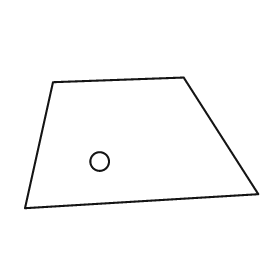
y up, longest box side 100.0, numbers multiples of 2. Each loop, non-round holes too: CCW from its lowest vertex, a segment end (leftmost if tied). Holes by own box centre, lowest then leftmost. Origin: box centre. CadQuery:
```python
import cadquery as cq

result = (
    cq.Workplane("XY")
    .moveTo(-50.0, -28.0)
    .lineTo(50.0, -22.0)
    .lineTo(18.0, 28.0)
    .lineTo(-38.0, 26.0)
    .close()
    .moveTo(-18.0, -8.0)
    .circle(4.0)
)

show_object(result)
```